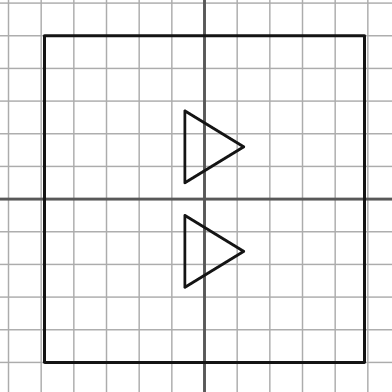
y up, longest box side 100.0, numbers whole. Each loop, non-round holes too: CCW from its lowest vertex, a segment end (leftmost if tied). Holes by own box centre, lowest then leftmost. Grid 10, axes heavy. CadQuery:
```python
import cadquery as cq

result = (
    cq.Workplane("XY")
    .moveTo(-49.0, -50.0)
    .lineTo(49.0, -50.0)
    .lineTo(49.0, 50.0)
    .lineTo(-49.0, 50.0)
    .close()
    .moveTo(-6.0, -27.0)
    .lineTo(12.0, -16.0)
    .lineTo(-6.0, -5.0)
    .close()
    .moveTo(-6.0, 5.0)
    .lineTo(12.0, 16.0)
    .lineTo(-6.0, 27.0)
    .close()
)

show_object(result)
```